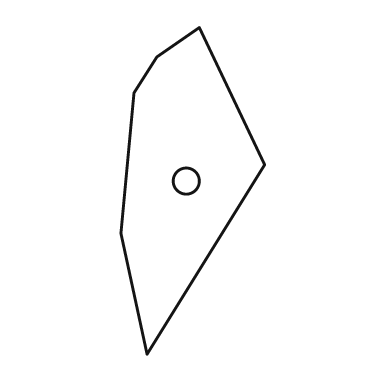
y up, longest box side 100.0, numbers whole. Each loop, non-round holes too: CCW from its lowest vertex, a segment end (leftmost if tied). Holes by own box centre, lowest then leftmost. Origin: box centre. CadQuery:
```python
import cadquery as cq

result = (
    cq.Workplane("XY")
    .moveTo(-14.0, -50.0)
    .lineTo(22.0, 8.0)
    .lineTo(2.0, 50.0)
    .lineTo(-11.0, 41.0)
    .lineTo(-18.0, 30.0)
    .lineTo(-22.0, -13.0)
    .close()
    .moveTo(-2.0, 3.0)
    .circle(4.0)
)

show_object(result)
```